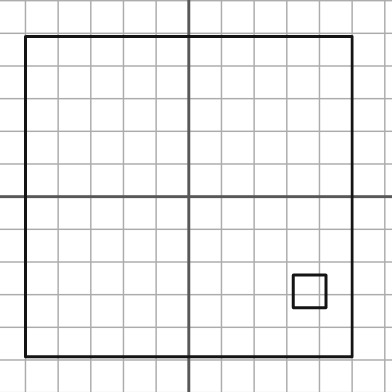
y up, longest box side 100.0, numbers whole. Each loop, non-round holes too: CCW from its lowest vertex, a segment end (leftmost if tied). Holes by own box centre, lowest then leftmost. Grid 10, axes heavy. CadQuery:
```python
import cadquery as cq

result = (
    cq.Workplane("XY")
    .moveTo(-50.0, -49.0)
    .lineTo(50.0, -49.0)
    .lineTo(50.0, 49.0)
    .lineTo(-50.0, 49.0)
    .close()
    .moveTo(32.0, -34.0)
    .lineTo(42.0, -34.0)
    .lineTo(42.0, -24.0)
    .lineTo(32.0, -24.0)
    .close()
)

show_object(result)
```